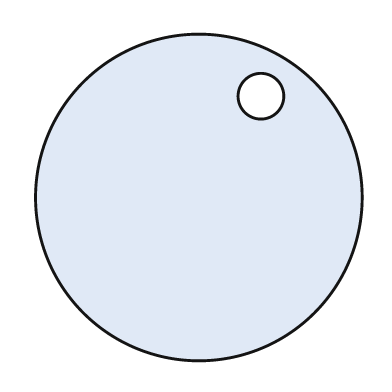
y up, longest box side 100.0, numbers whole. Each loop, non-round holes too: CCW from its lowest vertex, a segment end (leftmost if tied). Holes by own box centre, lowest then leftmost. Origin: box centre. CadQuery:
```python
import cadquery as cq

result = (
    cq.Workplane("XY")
    .moveTo(0.0, 0.0)
    .circle(50.0)
    .moveTo(19.0, 31.0)
    .circle(7.0)
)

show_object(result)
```